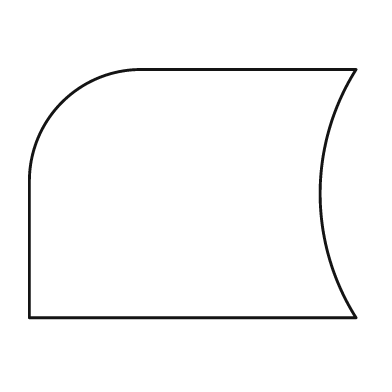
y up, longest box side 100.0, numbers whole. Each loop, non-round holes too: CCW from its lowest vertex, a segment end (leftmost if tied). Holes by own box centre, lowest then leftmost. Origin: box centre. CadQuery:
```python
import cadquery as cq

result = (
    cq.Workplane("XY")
    .moveTo(-50.0, -38.0)
    .lineTo(50.0, -38.0)
    .threePointArc((39.0, 0.0), (50.0, 38.0))
    .lineTo(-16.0, 38.0)
    .threePointArc((-40.0, 28.0), (-50.0, 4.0))
    .close()
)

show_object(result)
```